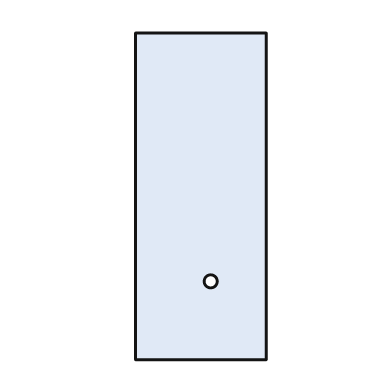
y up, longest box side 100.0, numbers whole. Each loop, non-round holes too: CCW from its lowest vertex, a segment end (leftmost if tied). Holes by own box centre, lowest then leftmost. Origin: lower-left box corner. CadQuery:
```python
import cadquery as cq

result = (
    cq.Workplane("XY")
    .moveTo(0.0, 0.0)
    .lineTo(40.0, 0.0)
    .lineTo(40.0, 100.0)
    .lineTo(0.0, 100.0)
    .close()
    .moveTo(23.0, 24.0)
    .circle(2.0)
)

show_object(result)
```